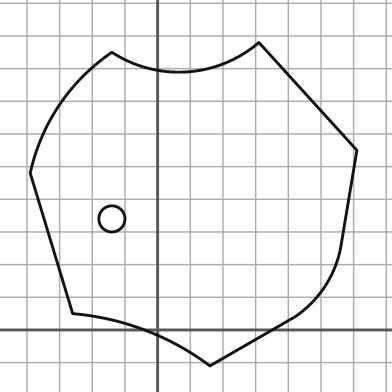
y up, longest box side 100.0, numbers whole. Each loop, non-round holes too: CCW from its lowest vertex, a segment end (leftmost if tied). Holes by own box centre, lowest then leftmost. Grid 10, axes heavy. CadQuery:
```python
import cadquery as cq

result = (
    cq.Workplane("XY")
    .moveTo(16.0, -11.0)
    .lineTo(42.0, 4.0)
    .threePointArc((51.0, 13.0), (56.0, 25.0))
    .lineTo(61.0, 55.0)
    .lineTo(31.0, 88.0)
    .threePointArc((9.0, 79.0), (-14.0, 85.0))
    .threePointArc((-30.0, 69.0), (-39.0, 48.0))
    .lineTo(-26.0, 5.0)
    .threePointArc((-4.0, 0.0), (16.0, -11.0))
    .close()
    .moveTo(-14.0, 34.0)
    .circle(4.0)
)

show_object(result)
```